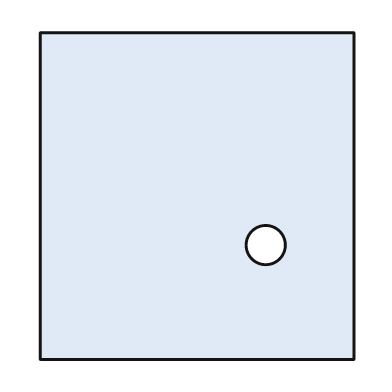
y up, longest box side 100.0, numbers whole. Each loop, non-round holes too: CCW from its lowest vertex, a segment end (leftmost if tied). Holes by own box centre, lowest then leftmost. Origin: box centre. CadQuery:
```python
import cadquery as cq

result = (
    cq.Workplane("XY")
    .moveTo(-48.0, -50.0)
    .lineTo(48.0, -50.0)
    .lineTo(48.0, 50.0)
    .lineTo(-48.0, 50.0)
    .close()
    .moveTo(21.0, -15.0)
    .circle(6.0)
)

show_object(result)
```